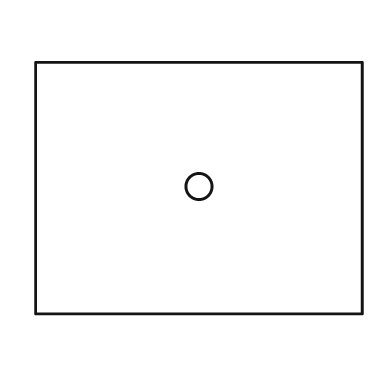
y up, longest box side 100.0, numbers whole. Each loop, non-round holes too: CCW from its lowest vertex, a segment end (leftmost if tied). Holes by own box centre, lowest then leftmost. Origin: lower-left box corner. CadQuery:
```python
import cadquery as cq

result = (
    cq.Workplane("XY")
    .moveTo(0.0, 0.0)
    .lineTo(100.0, 0.0)
    .lineTo(100.0, 77.0)
    .lineTo(0.0, 77.0)
    .close()
    .moveTo(50.0, 39.0)
    .circle(4.0)
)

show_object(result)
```